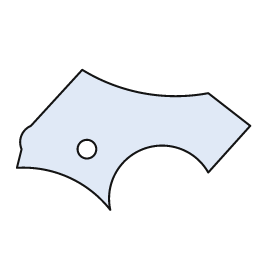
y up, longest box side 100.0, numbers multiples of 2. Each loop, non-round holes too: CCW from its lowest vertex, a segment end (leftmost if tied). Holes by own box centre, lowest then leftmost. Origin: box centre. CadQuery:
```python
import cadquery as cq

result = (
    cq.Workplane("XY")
    .moveTo(-10.0, -30.0)
    .threePointArc((4.0, -4.0), (32.0, -14.0))
    .lineTo(50.0, 6.0)
    .lineTo(32.0, 20.0)
    .threePointArc((4.0, 20.0), (-22.0, 30.0))
    .lineTo(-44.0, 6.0)
    .threePointArc((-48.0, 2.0), (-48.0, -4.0))
    .lineTo(-50.0, -12.0)
    .threePointArc((-28.0, -16.0), (-10.0, -30.0))
    .close()
    .moveTo(-20.0, -4.0)
    .circle(4.0)
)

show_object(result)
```